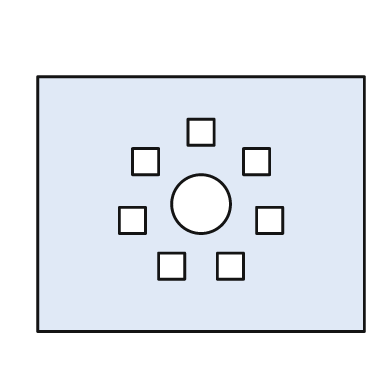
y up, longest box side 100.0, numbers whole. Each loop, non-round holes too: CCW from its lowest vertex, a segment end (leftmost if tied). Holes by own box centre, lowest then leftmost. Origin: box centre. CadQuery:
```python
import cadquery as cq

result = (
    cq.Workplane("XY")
    .moveTo(-50.0, -39.0)
    .lineTo(50.0, -39.0)
    .lineTo(50.0, 39.0)
    .lineTo(-50.0, 39.0)
    .close()
    .moveTo(-13.0, -23.0)
    .lineTo(-5.0, -23.0)
    .lineTo(-5.0, -15.0)
    .lineTo(-13.0, -15.0)
    .close()
    .moveTo(5.0, -23.0)
    .lineTo(13.0, -23.0)
    .lineTo(13.0, -15.0)
    .lineTo(5.0, -15.0)
    .close()
    .moveTo(-25.0, -9.0)
    .lineTo(-17.0, -9.0)
    .lineTo(-17.0, -1.0)
    .lineTo(-25.0, -1.0)
    .close()
    .moveTo(17.0, -9.0)
    .lineTo(25.0, -9.0)
    .lineTo(25.0, -1.0)
    .lineTo(17.0, -1.0)
    .close()
    .moveTo(0.0, 0.0)
    .circle(9.0)
    .moveTo(-21.0, 9.0)
    .lineTo(-13.0, 9.0)
    .lineTo(-13.0, 17.0)
    .lineTo(-21.0, 17.0)
    .close()
    .moveTo(13.0, 9.0)
    .lineTo(21.0, 9.0)
    .lineTo(21.0, 17.0)
    .lineTo(13.0, 17.0)
    .close()
    .moveTo(-4.0, 18.0)
    .lineTo(4.0, 18.0)
    .lineTo(4.0, 26.0)
    .lineTo(-4.0, 26.0)
    .close()
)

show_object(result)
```